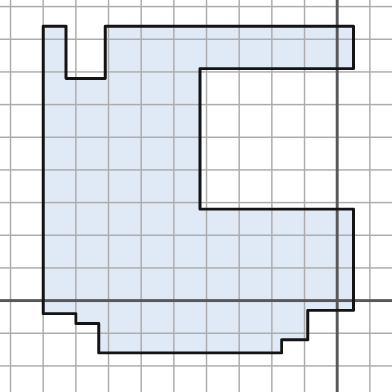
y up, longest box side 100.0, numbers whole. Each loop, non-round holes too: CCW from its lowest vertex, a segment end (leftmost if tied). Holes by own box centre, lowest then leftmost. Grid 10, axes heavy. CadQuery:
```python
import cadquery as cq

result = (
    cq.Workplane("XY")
    .moveTo(-73.0, -16.0)
    .lineTo(-17.0, -16.0)
    .lineTo(-17.0, -12.0)
    .lineTo(-9.0, -12.0)
    .lineTo(-9.0, -3.0)
    .lineTo(5.0, -3.0)
    .lineTo(5.0, 28.0)
    .lineTo(-42.0, 28.0)
    .lineTo(-42.0, 71.0)
    .lineTo(5.0, 71.0)
    .lineTo(5.0, 84.0)
    .lineTo(-71.0, 84.0)
    .lineTo(-71.0, 68.0)
    .lineTo(-83.0, 68.0)
    .lineTo(-83.0, 84.0)
    .lineTo(-90.0, 84.0)
    .lineTo(-90.0, -4.0)
    .lineTo(-80.0, -4.0)
    .lineTo(-80.0, -7.0)
    .lineTo(-73.0, -7.0)
    .close()
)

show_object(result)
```